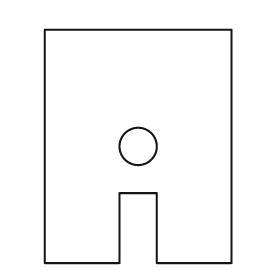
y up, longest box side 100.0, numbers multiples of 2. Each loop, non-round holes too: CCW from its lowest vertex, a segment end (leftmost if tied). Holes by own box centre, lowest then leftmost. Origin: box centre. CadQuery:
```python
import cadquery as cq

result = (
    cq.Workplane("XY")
    .moveTo(-40.0, -50.0)
    .lineTo(-8.0, -50.0)
    .lineTo(-8.0, -20.0)
    .lineTo(8.0, -20.0)
    .lineTo(8.0, -50.0)
    .lineTo(40.0, -50.0)
    .lineTo(40.0, 50.0)
    .lineTo(-40.0, 50.0)
    .close()
    .moveTo(0.0, 0.0)
    .circle(8.0)
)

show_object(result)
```